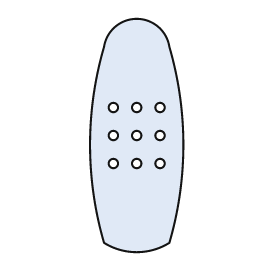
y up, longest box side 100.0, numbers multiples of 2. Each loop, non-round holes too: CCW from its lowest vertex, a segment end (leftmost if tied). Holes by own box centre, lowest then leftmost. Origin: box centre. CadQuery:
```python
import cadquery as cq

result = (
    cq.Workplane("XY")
    .moveTo(-14.0, -46.0)
    .threePointArc((0.0, -50.0), (14.0, -46.0))
    .threePointArc((20.0, -4.0), (14.0, 38.0))
    .threePointArc((0.0, 50.0), (-14.0, 38.0))
    .threePointArc((-20.0, -4.0), (-14.0, -46.0))
    .close()
    .moveTo(-10.0, -12.0)
    .circle(2.0)
    .moveTo(0.0, -12.0)
    .circle(2.0)
    .moveTo(10.0, -12.0)
    .circle(2.0)
    .moveTo(-10.0, 0.0)
    .circle(2.0)
    .moveTo(0.0, 0.0)
    .circle(2.0)
    .moveTo(10.0, 0.0)
    .circle(2.0)
    .moveTo(-10.0, 12.0)
    .circle(2.0)
    .moveTo(0.0, 12.0)
    .circle(2.0)
    .moveTo(10.0, 12.0)
    .circle(2.0)
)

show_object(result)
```